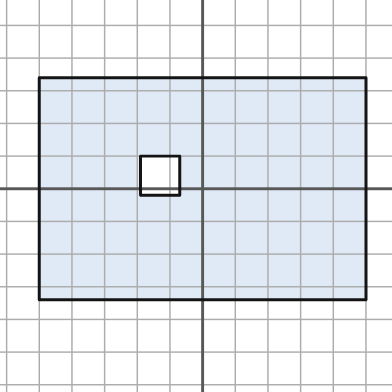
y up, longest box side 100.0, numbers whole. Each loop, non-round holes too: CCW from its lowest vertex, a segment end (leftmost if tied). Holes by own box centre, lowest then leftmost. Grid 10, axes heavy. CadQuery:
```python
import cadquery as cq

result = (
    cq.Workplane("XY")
    .moveTo(-50.0, -34.0)
    .lineTo(50.0, -34.0)
    .lineTo(50.0, 34.0)
    .lineTo(-50.0, 34.0)
    .close()
    .moveTo(-19.0, -2.0)
    .lineTo(-7.0, -2.0)
    .lineTo(-7.0, 10.0)
    .lineTo(-19.0, 10.0)
    .close()
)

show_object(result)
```